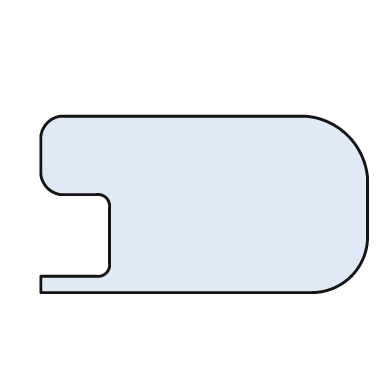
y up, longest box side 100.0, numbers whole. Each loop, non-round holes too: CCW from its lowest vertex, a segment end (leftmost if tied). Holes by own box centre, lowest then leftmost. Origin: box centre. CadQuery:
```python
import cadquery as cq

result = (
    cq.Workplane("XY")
    .moveTo(-50.0, -27.0)
    .lineTo(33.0, -27.0)
    .threePointArc((45.0, -22.0), (50.0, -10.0))
    .lineTo(50.0, 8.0)
    .threePointArc((44.0, 21.0), (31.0, 27.0))
    .lineTo(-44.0, 27.0)
    .threePointArc((-48.0, 25.0), (-50.0, 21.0))
    .lineTo(-50.0, 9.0)
    .threePointArc((-48.0, 5.0), (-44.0, 3.0))
    .lineTo(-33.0, 3.0)
    .threePointArc((-30.0, 2.0), (-29.0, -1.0))
    .lineTo(-29.0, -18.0)
    .threePointArc((-30.0, -21.0), (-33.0, -22.0))
    .lineTo(-50.0, -22.0)
    .close()
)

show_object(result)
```